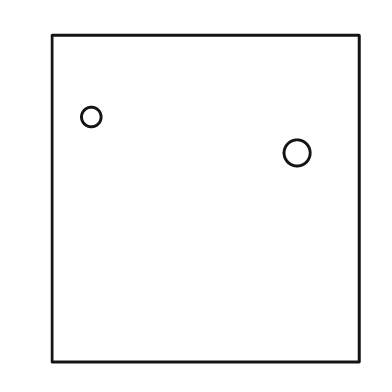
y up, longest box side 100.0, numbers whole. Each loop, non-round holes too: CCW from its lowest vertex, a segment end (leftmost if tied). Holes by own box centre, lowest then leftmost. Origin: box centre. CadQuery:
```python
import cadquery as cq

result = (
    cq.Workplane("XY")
    .moveTo(-47.0, -50.0)
    .lineTo(47.0, -50.0)
    .lineTo(47.0, 50.0)
    .lineTo(-47.0, 50.0)
    .close()
    .moveTo(28.0, 14.0)
    .circle(4.0)
    .moveTo(-35.0, 25.0)
    .circle(3.0)
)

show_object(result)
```